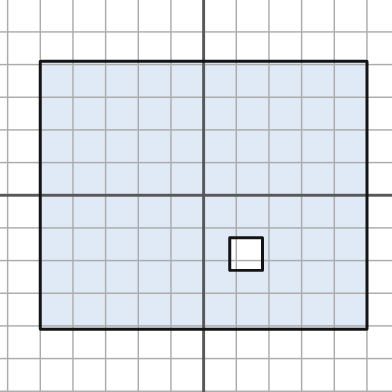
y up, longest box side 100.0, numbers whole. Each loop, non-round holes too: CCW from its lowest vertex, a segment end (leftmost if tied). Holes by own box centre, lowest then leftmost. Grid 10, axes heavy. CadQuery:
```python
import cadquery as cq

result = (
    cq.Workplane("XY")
    .moveTo(-50.0, -41.0)
    .lineTo(50.0, -41.0)
    .lineTo(50.0, 41.0)
    .lineTo(-50.0, 41.0)
    .close()
    .moveTo(8.0, -23.0)
    .lineTo(18.0, -23.0)
    .lineTo(18.0, -13.0)
    .lineTo(8.0, -13.0)
    .close()
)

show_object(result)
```